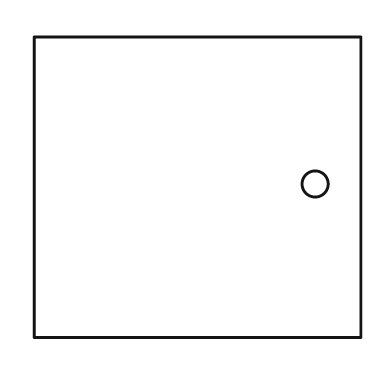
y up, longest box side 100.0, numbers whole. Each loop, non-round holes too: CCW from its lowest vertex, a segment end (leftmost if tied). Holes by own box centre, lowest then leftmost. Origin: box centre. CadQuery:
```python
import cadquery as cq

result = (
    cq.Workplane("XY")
    .moveTo(-50.0, -46.0)
    .lineTo(50.0, -46.0)
    .lineTo(50.0, 46.0)
    .lineTo(-50.0, 46.0)
    .close()
    .moveTo(36.0, 1.0)
    .circle(4.0)
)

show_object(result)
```